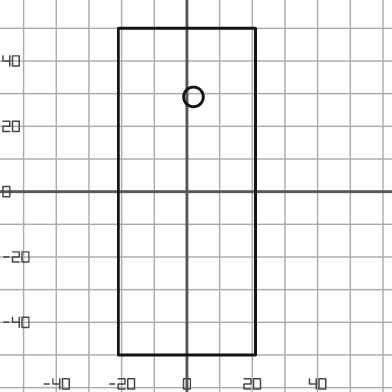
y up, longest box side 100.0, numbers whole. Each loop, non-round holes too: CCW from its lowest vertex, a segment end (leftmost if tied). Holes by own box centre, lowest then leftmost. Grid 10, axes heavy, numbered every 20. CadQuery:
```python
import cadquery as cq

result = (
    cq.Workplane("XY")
    .moveTo(-21.0, -50.0)
    .lineTo(21.0, -50.0)
    .lineTo(21.0, 50.0)
    .lineTo(-21.0, 50.0)
    .close()
    .moveTo(2.0, 29.0)
    .circle(3.0)
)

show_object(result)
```